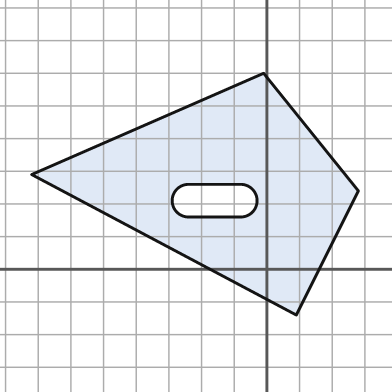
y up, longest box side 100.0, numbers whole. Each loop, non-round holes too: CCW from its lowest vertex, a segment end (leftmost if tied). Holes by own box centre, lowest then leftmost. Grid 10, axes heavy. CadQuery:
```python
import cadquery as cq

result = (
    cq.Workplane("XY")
    .moveTo(9.0, -14.0)
    .lineTo(28.0, 24.0)
    .lineTo(-1.0, 60.0)
    .lineTo(-72.0, 29.0)
    .close()
    .moveTo(-24.0, 16.0)
    .lineTo(-8.0, 16.0)
    .threePointArc((-3.0, 21.0), (-8.0, 26.0))
    .lineTo(-24.0, 26.0)
    .threePointArc((-29.0, 21.0), (-24.0, 16.0))
    .close()
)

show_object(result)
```